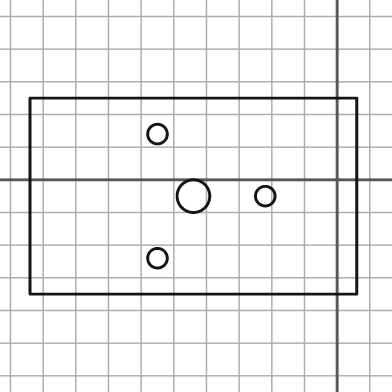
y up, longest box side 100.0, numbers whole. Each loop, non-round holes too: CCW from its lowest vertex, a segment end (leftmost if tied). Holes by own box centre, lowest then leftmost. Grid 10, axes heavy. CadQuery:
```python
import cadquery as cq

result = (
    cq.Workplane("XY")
    .moveTo(-94.0, -35.0)
    .lineTo(6.0, -35.0)
    .lineTo(6.0, 25.0)
    .lineTo(-94.0, 25.0)
    .close()
    .moveTo(-55.0, -24.0)
    .circle(3.0)
    .moveTo(-44.0, -5.0)
    .circle(5.0)
    .moveTo(-22.0, -5.0)
    .circle(3.0)
    .moveTo(-55.0, 14.0)
    .circle(3.0)
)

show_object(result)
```